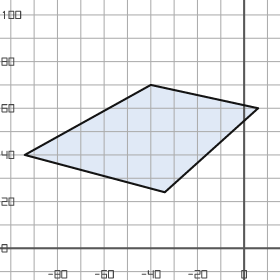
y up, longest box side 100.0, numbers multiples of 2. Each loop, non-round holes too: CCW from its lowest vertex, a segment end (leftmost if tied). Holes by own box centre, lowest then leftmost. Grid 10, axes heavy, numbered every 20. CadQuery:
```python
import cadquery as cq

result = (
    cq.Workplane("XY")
    .moveTo(-34.0, 24.0)
    .lineTo(6.0, 60.0)
    .lineTo(-40.0, 70.0)
    .lineTo(-94.0, 40.0)
    .close()
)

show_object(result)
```